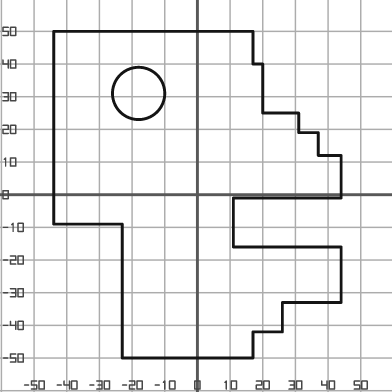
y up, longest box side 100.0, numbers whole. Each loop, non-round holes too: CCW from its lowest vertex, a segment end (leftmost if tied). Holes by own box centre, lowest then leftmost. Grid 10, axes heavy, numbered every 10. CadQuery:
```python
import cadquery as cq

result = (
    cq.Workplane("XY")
    .moveTo(-23.0, -50.0)
    .lineTo(17.0, -50.0)
    .lineTo(17.0, -42.0)
    .lineTo(26.0, -42.0)
    .lineTo(26.0, -33.0)
    .lineTo(44.0, -33.0)
    .lineTo(44.0, -16.0)
    .lineTo(11.0, -16.0)
    .lineTo(11.0, -1.0)
    .lineTo(44.0, -1.0)
    .lineTo(44.0, 12.0)
    .lineTo(37.0, 12.0)
    .lineTo(37.0, 19.0)
    .lineTo(31.0, 19.0)
    .lineTo(31.0, 25.0)
    .lineTo(20.0, 25.0)
    .lineTo(20.0, 40.0)
    .lineTo(17.0, 40.0)
    .lineTo(17.0, 50.0)
    .lineTo(-44.0, 50.0)
    .lineTo(-44.0, -9.0)
    .lineTo(-23.0, -9.0)
    .close()
    .moveTo(-18.0, 31.0)
    .circle(8.0)
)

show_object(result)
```